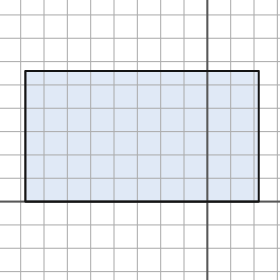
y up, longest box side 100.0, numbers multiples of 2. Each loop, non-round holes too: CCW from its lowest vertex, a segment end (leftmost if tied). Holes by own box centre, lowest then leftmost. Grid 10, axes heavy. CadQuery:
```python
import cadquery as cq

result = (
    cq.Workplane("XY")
    .moveTo(-78.0, 0.0)
    .lineTo(22.0, 0.0)
    .lineTo(22.0, 56.0)
    .lineTo(-78.0, 56.0)
    .close()
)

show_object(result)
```